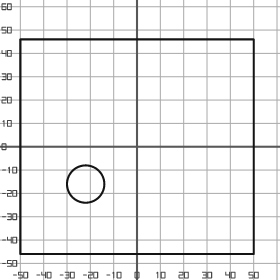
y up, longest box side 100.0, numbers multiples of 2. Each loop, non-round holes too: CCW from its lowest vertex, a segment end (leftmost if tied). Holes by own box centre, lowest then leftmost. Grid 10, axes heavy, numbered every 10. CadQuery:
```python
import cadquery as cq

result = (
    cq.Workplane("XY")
    .moveTo(-50.0, -46.0)
    .lineTo(50.0, -46.0)
    .lineTo(50.0, 46.0)
    .lineTo(-50.0, 46.0)
    .close()
    .moveTo(-22.0, -16.0)
    .circle(8.0)
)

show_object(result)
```